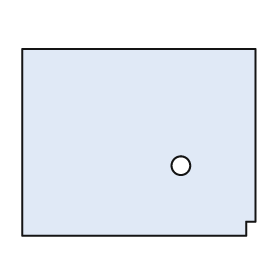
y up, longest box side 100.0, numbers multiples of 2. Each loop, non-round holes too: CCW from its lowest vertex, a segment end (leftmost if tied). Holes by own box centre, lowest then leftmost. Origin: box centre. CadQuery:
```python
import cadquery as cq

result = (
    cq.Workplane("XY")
    .moveTo(-50.0, -40.0)
    .lineTo(46.0, -40.0)
    .lineTo(46.0, -34.0)
    .lineTo(50.0, -34.0)
    .lineTo(50.0, 40.0)
    .lineTo(-50.0, 40.0)
    .close()
    .moveTo(18.0, -10.0)
    .circle(4.0)
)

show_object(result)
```